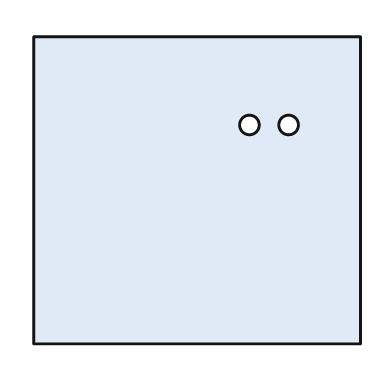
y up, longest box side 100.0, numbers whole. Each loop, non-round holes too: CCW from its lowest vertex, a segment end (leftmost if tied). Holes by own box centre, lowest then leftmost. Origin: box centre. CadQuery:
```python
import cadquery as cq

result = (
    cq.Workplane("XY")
    .moveTo(-50.0, -47.0)
    .lineTo(50.0, -47.0)
    .lineTo(50.0, 47.0)
    .lineTo(-50.0, 47.0)
    .close()
    .moveTo(16.0, 20.0)
    .circle(3.0)
    .moveTo(28.0, 20.0)
    .circle(3.0)
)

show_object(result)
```